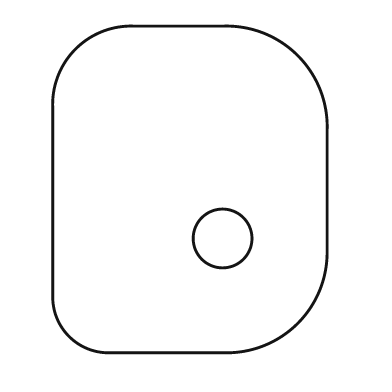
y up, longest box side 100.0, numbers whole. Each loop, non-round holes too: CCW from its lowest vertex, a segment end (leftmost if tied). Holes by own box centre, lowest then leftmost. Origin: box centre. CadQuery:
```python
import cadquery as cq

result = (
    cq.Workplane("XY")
    .moveTo(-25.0, -50.0)
    .lineTo(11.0, -50.0)
    .threePointArc((33.0, -41.0), (42.0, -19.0))
    .lineTo(42.0, 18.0)
    .threePointArc((33.0, 41.0), (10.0, 50.0))
    .lineTo(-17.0, 50.0)
    .threePointArc((-35.0, 43.0), (-42.0, 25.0))
    .lineTo(-42.0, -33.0)
    .threePointArc((-37.0, -45.0), (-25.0, -50.0))
    .close()
    .moveTo(10.0, -15.0)
    .circle(9.0)
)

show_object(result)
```